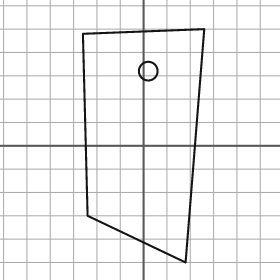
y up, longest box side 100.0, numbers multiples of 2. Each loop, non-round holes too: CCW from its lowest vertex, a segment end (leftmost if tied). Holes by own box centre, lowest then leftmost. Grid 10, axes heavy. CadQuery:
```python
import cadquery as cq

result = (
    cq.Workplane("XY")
    .moveTo(18.0, -50.0)
    .lineTo(26.0, 50.0)
    .lineTo(-26.0, 48.0)
    .lineTo(-24.0, -30.0)
    .close()
    .moveTo(2.0, 32.0)
    .circle(4.0)
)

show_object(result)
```